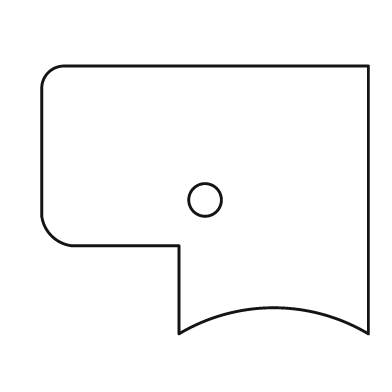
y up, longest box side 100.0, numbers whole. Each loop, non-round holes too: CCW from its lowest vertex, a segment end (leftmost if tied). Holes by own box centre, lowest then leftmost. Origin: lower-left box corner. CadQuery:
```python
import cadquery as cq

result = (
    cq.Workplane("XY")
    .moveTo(42.0, 0.0)
    .threePointArc((71.0, 8.0), (100.0, 0.0))
    .lineTo(100.0, 82.0)
    .lineTo(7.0, 82.0)
    .threePointArc((2.0, 80.0), (0.0, 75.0))
    .lineTo(0.0, 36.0)
    .threePointArc((3.0, 30.0), (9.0, 27.0))
    .lineTo(42.0, 27.0)
    .close()
    .moveTo(50.0, 41.0)
    .circle(5.0)
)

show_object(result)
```